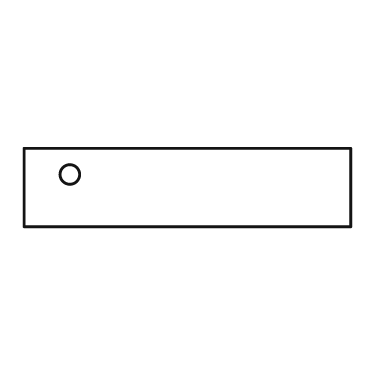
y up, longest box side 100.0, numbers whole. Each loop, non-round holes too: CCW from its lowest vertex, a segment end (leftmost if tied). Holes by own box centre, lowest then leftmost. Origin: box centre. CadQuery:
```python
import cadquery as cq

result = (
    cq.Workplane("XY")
    .moveTo(-50.0, -12.0)
    .lineTo(50.0, -12.0)
    .lineTo(50.0, 12.0)
    .lineTo(-50.0, 12.0)
    .close()
    .moveTo(-36.0, 4.0)
    .circle(3.0)
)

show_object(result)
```